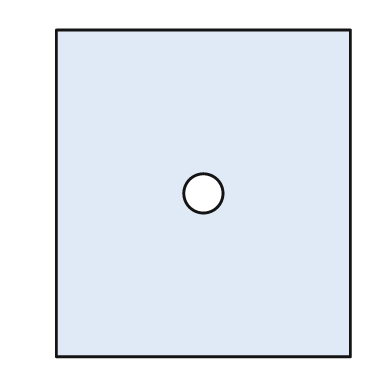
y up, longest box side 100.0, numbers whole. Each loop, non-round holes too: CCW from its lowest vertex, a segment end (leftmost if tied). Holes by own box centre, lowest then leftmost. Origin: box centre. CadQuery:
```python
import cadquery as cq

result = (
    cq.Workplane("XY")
    .moveTo(-45.0, -50.0)
    .lineTo(45.0, -50.0)
    .lineTo(45.0, 50.0)
    .lineTo(-45.0, 50.0)
    .close()
    .moveTo(0.0, 0.0)
    .circle(6.0)
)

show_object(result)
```